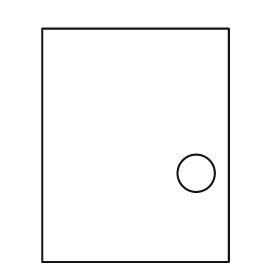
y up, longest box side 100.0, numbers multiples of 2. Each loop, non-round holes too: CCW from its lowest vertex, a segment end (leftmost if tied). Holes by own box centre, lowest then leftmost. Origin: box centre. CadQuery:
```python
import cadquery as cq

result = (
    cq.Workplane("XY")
    .moveTo(-40.0, -50.0)
    .lineTo(40.0, -50.0)
    .lineTo(40.0, 50.0)
    .lineTo(-40.0, 50.0)
    .close()
    .moveTo(26.0, -12.0)
    .circle(8.0)
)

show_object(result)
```